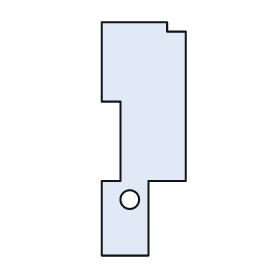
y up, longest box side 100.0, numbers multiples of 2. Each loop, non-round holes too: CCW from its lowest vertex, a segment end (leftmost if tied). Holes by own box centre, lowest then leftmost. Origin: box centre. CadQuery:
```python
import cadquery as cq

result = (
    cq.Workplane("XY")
    .moveTo(-18.0, -50.0)
    .lineTo(2.0, -50.0)
    .lineTo(2.0, -18.0)
    .lineTo(18.0, -18.0)
    .lineTo(18.0, 46.0)
    .lineTo(10.0, 46.0)
    .lineTo(10.0, 50.0)
    .lineTo(-18.0, 50.0)
    .lineTo(-18.0, 16.0)
    .lineTo(-10.0, 16.0)
    .lineTo(-10.0, -18.0)
    .lineTo(-18.0, -18.0)
    .close()
    .moveTo(-6.0, -26.0)
    .circle(4.0)
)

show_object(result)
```